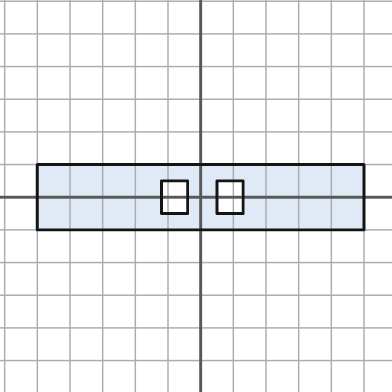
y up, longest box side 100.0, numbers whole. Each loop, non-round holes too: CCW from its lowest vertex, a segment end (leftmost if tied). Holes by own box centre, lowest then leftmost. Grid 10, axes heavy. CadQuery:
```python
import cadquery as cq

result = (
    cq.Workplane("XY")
    .moveTo(-50.0, -10.0)
    .lineTo(50.0, -10.0)
    .lineTo(50.0, 10.0)
    .lineTo(-50.0, 10.0)
    .close()
    .moveTo(-12.0, -5.0)
    .lineTo(-4.0, -5.0)
    .lineTo(-4.0, 5.0)
    .lineTo(-12.0, 5.0)
    .close()
    .moveTo(5.0, -5.0)
    .lineTo(13.0, -5.0)
    .lineTo(13.0, 5.0)
    .lineTo(5.0, 5.0)
    .close()
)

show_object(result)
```